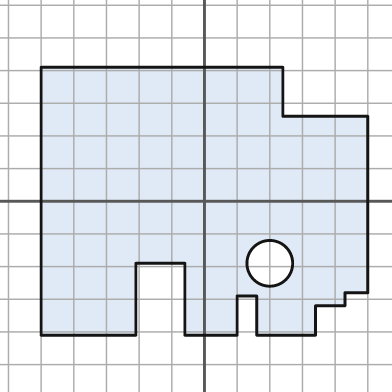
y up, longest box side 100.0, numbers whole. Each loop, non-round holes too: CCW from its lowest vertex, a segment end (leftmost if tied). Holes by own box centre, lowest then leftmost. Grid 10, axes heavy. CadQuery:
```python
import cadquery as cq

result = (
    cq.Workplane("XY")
    .moveTo(-50.0, -41.0)
    .lineTo(-21.0, -41.0)
    .lineTo(-21.0, -19.0)
    .lineTo(-6.0, -19.0)
    .lineTo(-6.0, -41.0)
    .lineTo(10.0, -41.0)
    .lineTo(10.0, -29.0)
    .lineTo(16.0, -29.0)
    .lineTo(16.0, -41.0)
    .lineTo(34.0, -41.0)
    .lineTo(34.0, -32.0)
    .lineTo(43.0, -32.0)
    .lineTo(43.0, -28.0)
    .lineTo(50.0, -28.0)
    .lineTo(50.0, 26.0)
    .lineTo(24.0, 26.0)
    .lineTo(24.0, 41.0)
    .lineTo(-50.0, 41.0)
    .close()
    .moveTo(20.0, -19.0)
    .circle(7.0)
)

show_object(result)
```